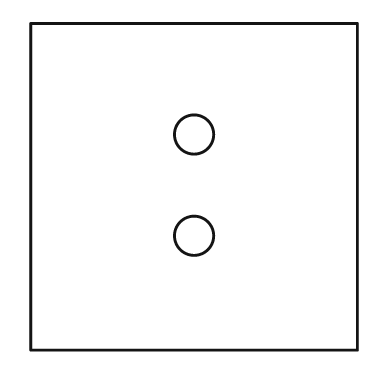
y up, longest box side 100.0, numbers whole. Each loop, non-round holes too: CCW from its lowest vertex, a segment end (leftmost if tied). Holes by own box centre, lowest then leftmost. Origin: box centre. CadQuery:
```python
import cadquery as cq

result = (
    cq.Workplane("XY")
    .moveTo(-50.0, -50.0)
    .lineTo(50.0, -50.0)
    .lineTo(50.0, 50.0)
    .lineTo(-50.0, 50.0)
    .close()
    .moveTo(0.0, -15.0)
    .circle(6.0)
    .moveTo(0.0, 16.0)
    .circle(6.0)
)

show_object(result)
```